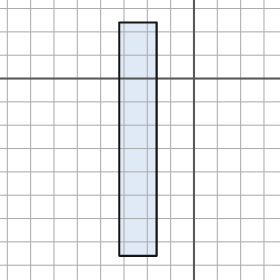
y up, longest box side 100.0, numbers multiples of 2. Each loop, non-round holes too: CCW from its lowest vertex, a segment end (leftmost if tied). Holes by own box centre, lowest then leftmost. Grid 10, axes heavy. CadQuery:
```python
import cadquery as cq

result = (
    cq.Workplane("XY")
    .moveTo(-32.0, -76.0)
    .lineTo(-16.0, -76.0)
    .lineTo(-16.0, 24.0)
    .lineTo(-32.0, 24.0)
    .close()
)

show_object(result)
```